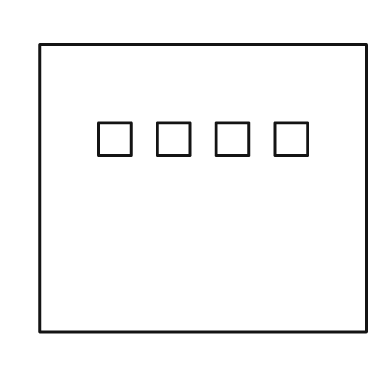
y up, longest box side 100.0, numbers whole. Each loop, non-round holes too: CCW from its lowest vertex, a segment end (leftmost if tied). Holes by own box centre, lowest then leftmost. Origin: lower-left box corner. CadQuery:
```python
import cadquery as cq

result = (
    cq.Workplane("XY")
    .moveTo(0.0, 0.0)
    .lineTo(100.0, 0.0)
    .lineTo(100.0, 88.0)
    .lineTo(0.0, 88.0)
    .close()
    .moveTo(18.0, 54.0)
    .lineTo(28.0, 54.0)
    .lineTo(28.0, 64.0)
    .lineTo(18.0, 64.0)
    .close()
    .moveTo(36.0, 54.0)
    .lineTo(46.0, 54.0)
    .lineTo(46.0, 64.0)
    .lineTo(36.0, 64.0)
    .close()
    .moveTo(54.0, 54.0)
    .lineTo(64.0, 54.0)
    .lineTo(64.0, 64.0)
    .lineTo(54.0, 64.0)
    .close()
    .moveTo(72.0, 54.0)
    .lineTo(82.0, 54.0)
    .lineTo(82.0, 64.0)
    .lineTo(72.0, 64.0)
    .close()
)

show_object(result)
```